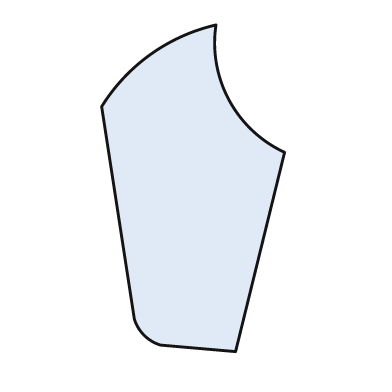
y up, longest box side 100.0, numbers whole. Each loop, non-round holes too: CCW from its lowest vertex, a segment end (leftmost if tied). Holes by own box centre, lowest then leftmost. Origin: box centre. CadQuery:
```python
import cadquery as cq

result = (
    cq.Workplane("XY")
    .moveTo(13.0, -50.0)
    .lineTo(28.0, 11.0)
    .threePointArc((11.0, 27.0), (7.0, 50.0))
    .threePointArc((-13.0, 41.0), (-28.0, 25.0))
    .lineTo(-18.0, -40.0)
    .threePointArc((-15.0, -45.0), (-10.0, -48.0))
    .close()
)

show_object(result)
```